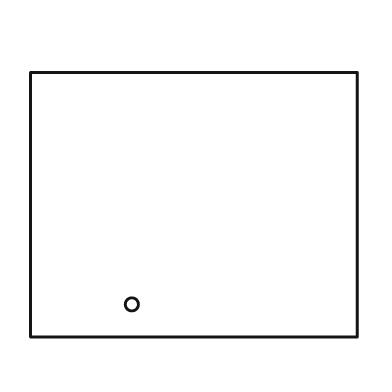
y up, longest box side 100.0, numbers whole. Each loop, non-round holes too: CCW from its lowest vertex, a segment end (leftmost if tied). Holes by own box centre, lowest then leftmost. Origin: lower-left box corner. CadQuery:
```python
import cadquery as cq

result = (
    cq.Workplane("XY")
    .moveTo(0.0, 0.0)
    .lineTo(100.0, 0.0)
    .lineTo(100.0, 81.0)
    .lineTo(0.0, 81.0)
    .close()
    .moveTo(31.0, 10.0)
    .circle(2.0)
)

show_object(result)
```